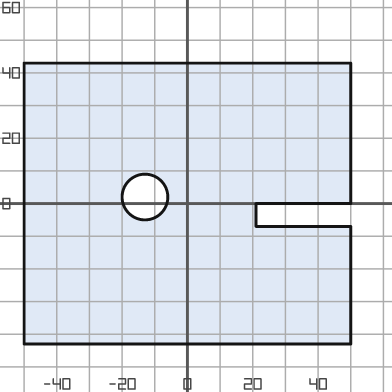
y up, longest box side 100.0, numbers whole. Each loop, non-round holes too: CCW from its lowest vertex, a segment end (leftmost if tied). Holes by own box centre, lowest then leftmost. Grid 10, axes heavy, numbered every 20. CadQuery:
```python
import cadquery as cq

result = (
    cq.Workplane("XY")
    .moveTo(-50.0, -43.0)
    .lineTo(50.0, -43.0)
    .lineTo(50.0, -7.0)
    .lineTo(21.0, -7.0)
    .lineTo(21.0, 0.0)
    .lineTo(50.0, 0.0)
    .lineTo(50.0, 43.0)
    .lineTo(-50.0, 43.0)
    .close()
    .moveTo(-13.0, 2.0)
    .circle(7.0)
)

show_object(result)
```